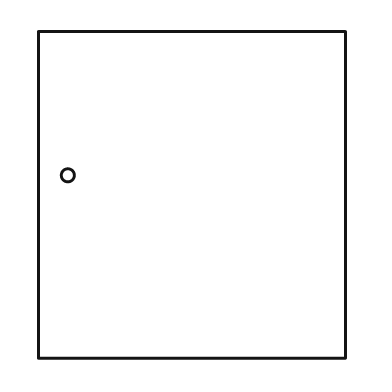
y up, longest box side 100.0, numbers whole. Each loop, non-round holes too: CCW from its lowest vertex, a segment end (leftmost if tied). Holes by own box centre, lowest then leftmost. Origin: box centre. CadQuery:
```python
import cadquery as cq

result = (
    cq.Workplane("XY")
    .moveTo(-47.0, -50.0)
    .lineTo(47.0, -50.0)
    .lineTo(47.0, 50.0)
    .lineTo(-47.0, 50.0)
    .close()
    .moveTo(-38.0, 6.0)
    .circle(2.0)
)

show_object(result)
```